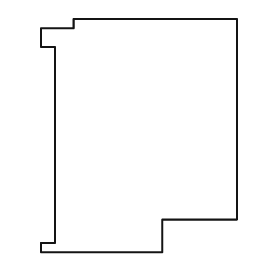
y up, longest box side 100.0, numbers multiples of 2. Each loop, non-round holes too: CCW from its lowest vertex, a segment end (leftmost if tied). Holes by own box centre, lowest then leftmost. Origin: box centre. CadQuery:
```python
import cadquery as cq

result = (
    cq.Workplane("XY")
    .moveTo(-42.0, -50.0)
    .lineTo(10.0, -50.0)
    .lineTo(10.0, -36.0)
    .lineTo(42.0, -36.0)
    .lineTo(42.0, 50.0)
    .lineTo(-28.0, 50.0)
    .lineTo(-28.0, 46.0)
    .lineTo(-42.0, 46.0)
    .lineTo(-42.0, 38.0)
    .lineTo(-36.0, 38.0)
    .lineTo(-36.0, -46.0)
    .lineTo(-42.0, -46.0)
    .close()
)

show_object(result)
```